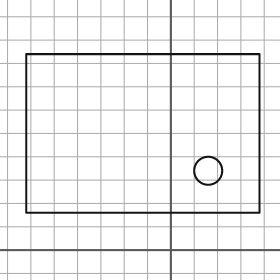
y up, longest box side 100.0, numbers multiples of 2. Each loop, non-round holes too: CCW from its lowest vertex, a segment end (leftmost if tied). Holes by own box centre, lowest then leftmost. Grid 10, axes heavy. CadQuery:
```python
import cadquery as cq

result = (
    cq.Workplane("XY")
    .moveTo(-62.0, 16.0)
    .lineTo(38.0, 16.0)
    .lineTo(38.0, 84.0)
    .lineTo(-62.0, 84.0)
    .close()
    .moveTo(16.0, 34.0)
    .circle(6.0)
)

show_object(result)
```